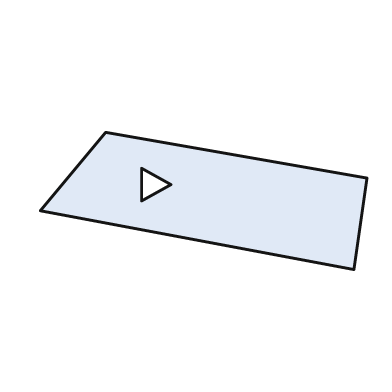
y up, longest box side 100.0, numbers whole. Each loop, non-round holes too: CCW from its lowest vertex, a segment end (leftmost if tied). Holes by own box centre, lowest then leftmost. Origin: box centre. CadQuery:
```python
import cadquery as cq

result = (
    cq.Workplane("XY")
    .moveTo(46.0, -21.0)
    .lineTo(50.0, 7.0)
    .lineTo(-30.0, 21.0)
    .lineTo(-50.0, -3.0)
    .close()
    .moveTo(-19.0, 0.0)
    .lineTo(-10.0, 5.0)
    .lineTo(-19.0, 10.0)
    .close()
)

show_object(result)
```